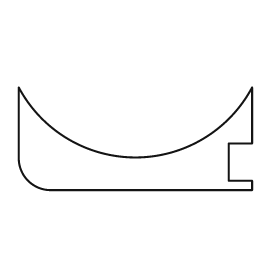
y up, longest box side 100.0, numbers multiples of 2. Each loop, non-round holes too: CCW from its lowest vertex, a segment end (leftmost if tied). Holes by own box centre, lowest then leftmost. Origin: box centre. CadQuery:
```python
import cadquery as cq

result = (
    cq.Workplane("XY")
    .moveTo(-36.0, -22.0)
    .lineTo(50.0, -22.0)
    .lineTo(50.0, -18.0)
    .lineTo(40.0, -18.0)
    .lineTo(40.0, -2.0)
    .lineTo(50.0, -2.0)
    .lineTo(50.0, 22.0)
    .threePointArc((0.0, -8.0), (-50.0, 22.0))
    .lineTo(-50.0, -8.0)
    .threePointArc((-46.0, -18.0), (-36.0, -22.0))
    .close()
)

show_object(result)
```